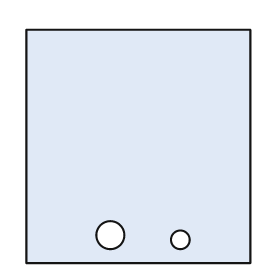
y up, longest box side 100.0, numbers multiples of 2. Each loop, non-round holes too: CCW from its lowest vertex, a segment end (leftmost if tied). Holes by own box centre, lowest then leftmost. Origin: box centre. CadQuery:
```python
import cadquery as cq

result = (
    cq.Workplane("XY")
    .moveTo(-48.0, -50.0)
    .lineTo(48.0, -50.0)
    .lineTo(48.0, 50.0)
    .lineTo(-48.0, 50.0)
    .close()
    .moveTo(18.0, -40.0)
    .circle(4.0)
    .moveTo(-12.0, -38.0)
    .circle(6.0)
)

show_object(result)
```